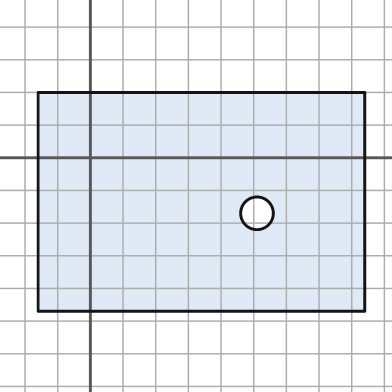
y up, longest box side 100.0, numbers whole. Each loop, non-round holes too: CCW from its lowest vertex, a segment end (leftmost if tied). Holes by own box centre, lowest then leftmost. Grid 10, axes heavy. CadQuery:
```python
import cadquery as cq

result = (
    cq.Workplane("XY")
    .moveTo(-16.0, -47.0)
    .lineTo(84.0, -47.0)
    .lineTo(84.0, 20.0)
    .lineTo(-16.0, 20.0)
    .close()
    .moveTo(51.0, -17.0)
    .circle(5.0)
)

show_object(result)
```